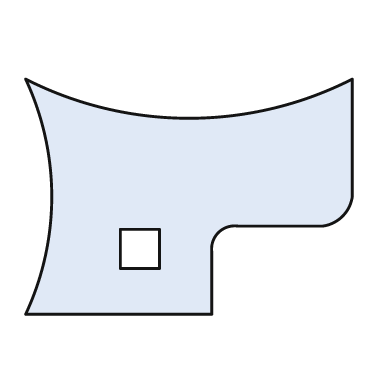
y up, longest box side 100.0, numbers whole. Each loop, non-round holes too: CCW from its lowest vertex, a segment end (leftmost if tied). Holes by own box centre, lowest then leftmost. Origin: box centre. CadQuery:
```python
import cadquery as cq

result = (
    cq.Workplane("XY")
    .moveTo(-50.0, -36.0)
    .lineTo(7.0, -36.0)
    .lineTo(7.0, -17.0)
    .threePointArc((9.0, -11.0), (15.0, -9.0))
    .lineTo(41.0, -9.0)
    .threePointArc((47.0, -6.0), (50.0, 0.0))
    .lineTo(50.0, 36.0)
    .threePointArc((0.0, 24.0), (-50.0, 36.0))
    .threePointArc((-42.0, 0.0), (-50.0, -36.0))
    .close()
    .moveTo(-21.0, -22.0)
    .lineTo(-9.0, -22.0)
    .lineTo(-9.0, -10.0)
    .lineTo(-21.0, -10.0)
    .close()
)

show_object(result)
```